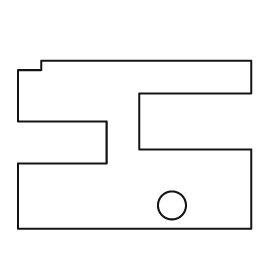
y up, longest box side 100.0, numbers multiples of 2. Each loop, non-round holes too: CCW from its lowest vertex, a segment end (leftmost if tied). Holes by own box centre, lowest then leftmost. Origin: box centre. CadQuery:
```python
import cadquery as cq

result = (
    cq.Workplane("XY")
    .moveTo(-50.0, -36.0)
    .lineTo(50.0, -36.0)
    .lineTo(50.0, -2.0)
    .lineTo(2.0, -2.0)
    .lineTo(2.0, 22.0)
    .lineTo(50.0, 22.0)
    .lineTo(50.0, 36.0)
    .lineTo(-40.0, 36.0)
    .lineTo(-40.0, 32.0)
    .lineTo(-50.0, 32.0)
    .lineTo(-50.0, 10.0)
    .lineTo(-12.0, 10.0)
    .lineTo(-12.0, -8.0)
    .lineTo(-50.0, -8.0)
    .close()
    .moveTo(16.0, -26.0)
    .circle(6.0)
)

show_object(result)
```